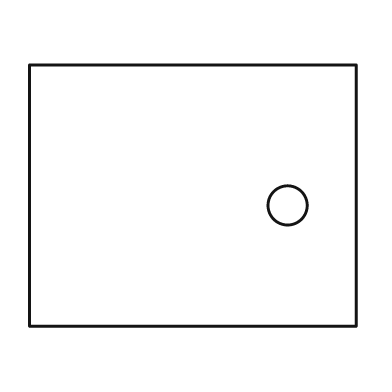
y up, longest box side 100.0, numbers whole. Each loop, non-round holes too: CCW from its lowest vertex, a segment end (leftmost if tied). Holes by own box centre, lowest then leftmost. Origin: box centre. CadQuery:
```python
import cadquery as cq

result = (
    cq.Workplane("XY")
    .moveTo(-50.0, -40.0)
    .lineTo(50.0, -40.0)
    .lineTo(50.0, 40.0)
    .lineTo(-50.0, 40.0)
    .close()
    .moveTo(29.0, -3.0)
    .circle(6.0)
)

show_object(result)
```